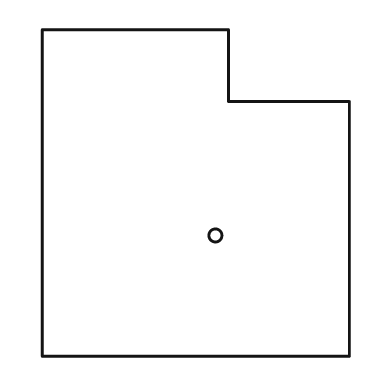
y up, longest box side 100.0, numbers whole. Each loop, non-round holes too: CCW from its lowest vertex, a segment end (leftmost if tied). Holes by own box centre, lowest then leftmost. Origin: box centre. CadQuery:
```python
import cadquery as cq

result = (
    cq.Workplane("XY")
    .moveTo(-47.0, -50.0)
    .lineTo(47.0, -50.0)
    .lineTo(47.0, 28.0)
    .lineTo(10.0, 28.0)
    .lineTo(10.0, 50.0)
    .lineTo(-47.0, 50.0)
    .close()
    .moveTo(6.0, -13.0)
    .circle(2.0)
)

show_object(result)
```